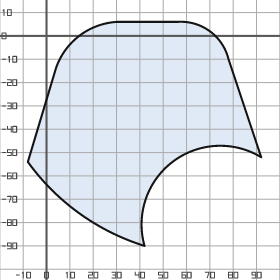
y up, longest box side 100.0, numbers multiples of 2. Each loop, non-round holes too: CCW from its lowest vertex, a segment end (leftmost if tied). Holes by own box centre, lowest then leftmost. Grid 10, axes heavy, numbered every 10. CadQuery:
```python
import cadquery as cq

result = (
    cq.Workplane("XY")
    .moveTo(42.0, -90.0)
    .threePointArc((54.0, -54.0), (92.0, -52.0))
    .lineTo(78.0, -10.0)
    .threePointArc((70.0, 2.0), (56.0, 6.0))
    .lineTo(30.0, 6.0)
    .threePointArc((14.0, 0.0), (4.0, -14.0))
    .lineTo(-8.0, -54.0)
    .threePointArc((14.0, -76.0), (42.0, -90.0))
    .close()
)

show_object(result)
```